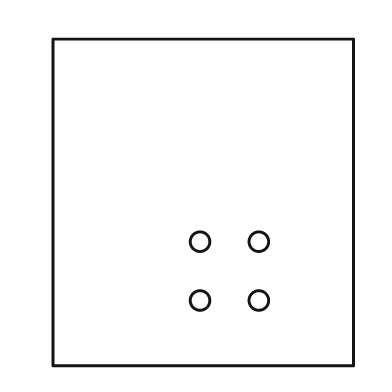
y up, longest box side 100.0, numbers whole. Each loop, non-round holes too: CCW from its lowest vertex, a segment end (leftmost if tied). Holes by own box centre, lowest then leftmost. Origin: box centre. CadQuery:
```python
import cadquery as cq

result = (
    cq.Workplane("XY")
    .moveTo(-46.0, -50.0)
    .lineTo(46.0, -50.0)
    .lineTo(46.0, 50.0)
    .lineTo(-46.0, 50.0)
    .close()
    .moveTo(-1.0, -30.0)
    .circle(3.0)
    .moveTo(17.0, -30.0)
    .circle(3.0)
    .moveTo(-1.0, -12.0)
    .circle(3.0)
    .moveTo(17.0, -12.0)
    .circle(3.0)
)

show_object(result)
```